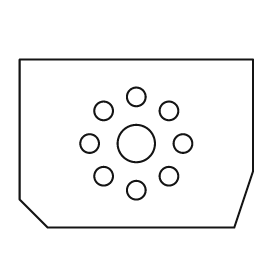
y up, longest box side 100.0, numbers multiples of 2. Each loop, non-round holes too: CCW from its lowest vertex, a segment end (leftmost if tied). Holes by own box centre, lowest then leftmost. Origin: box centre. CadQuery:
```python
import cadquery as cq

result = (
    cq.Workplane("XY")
    .moveTo(-38.0, -36.0)
    .lineTo(42.0, -36.0)
    .lineTo(50.0, -12.0)
    .lineTo(50.0, 36.0)
    .lineTo(-50.0, 36.0)
    .lineTo(-50.0, -24.0)
    .close()
    .moveTo(0.0, -20.0)
    .circle(4.0)
    .moveTo(-14.0, -14.0)
    .circle(4.0)
    .moveTo(14.0, -14.0)
    .circle(4.0)
    .moveTo(-20.0, 0.0)
    .circle(4.0)
    .moveTo(0.0, 0.0)
    .circle(8.0)
    .moveTo(20.0, 0.0)
    .circle(4.0)
    .moveTo(-14.0, 14.0)
    .circle(4.0)
    .moveTo(14.0, 14.0)
    .circle(4.0)
    .moveTo(0.0, 20.0)
    .circle(4.0)
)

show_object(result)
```